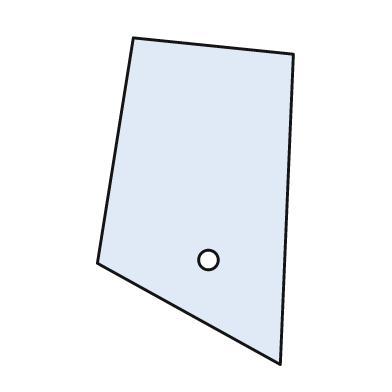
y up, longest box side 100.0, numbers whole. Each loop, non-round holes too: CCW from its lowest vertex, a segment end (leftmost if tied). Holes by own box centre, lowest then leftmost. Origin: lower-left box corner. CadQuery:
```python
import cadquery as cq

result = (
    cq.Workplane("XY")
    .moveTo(56.0, 0.0)
    .lineTo(60.0, 95.0)
    .lineTo(11.0, 100.0)
    .lineTo(0.0, 31.0)
    .close()
    .moveTo(34.0, 32.0)
    .circle(3.0)
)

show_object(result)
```